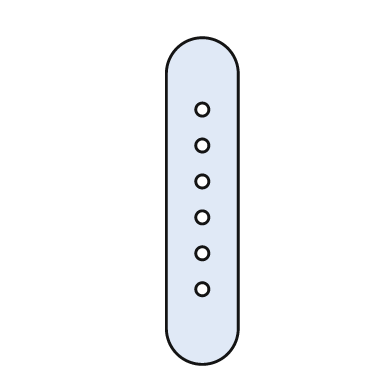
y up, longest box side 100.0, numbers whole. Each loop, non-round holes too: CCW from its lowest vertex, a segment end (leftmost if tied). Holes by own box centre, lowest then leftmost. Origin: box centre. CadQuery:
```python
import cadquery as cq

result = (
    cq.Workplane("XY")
    .moveTo(-11.0, -39.0)
    .threePointArc((0.0, -50.0), (11.0, -39.0))
    .lineTo(11.0, 39.0)
    .threePointArc((0.0, 50.0), (-11.0, 39.0))
    .close()
    .moveTo(0.0, -27.0)
    .circle(2.0)
    .moveTo(0.0, -16.0)
    .circle(2.0)
    .moveTo(0.0, -5.0)
    .circle(2.0)
    .moveTo(0.0, 6.0)
    .circle(2.0)
    .moveTo(0.0, 17.0)
    .circle(2.0)
    .moveTo(0.0, 28.0)
    .circle(2.0)
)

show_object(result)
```